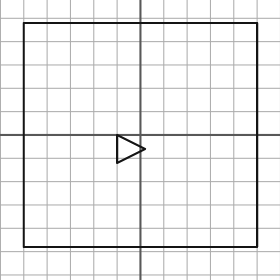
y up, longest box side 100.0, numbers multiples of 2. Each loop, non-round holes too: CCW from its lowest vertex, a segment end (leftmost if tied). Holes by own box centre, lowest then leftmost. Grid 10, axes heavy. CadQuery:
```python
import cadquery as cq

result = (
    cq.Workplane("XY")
    .moveTo(-50.0, -48.0)
    .lineTo(50.0, -48.0)
    .lineTo(50.0, 48.0)
    .lineTo(-50.0, 48.0)
    .close()
    .moveTo(-10.0, -12.0)
    .lineTo(2.0, -6.0)
    .lineTo(-10.0, 0.0)
    .close()
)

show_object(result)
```